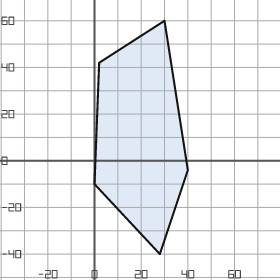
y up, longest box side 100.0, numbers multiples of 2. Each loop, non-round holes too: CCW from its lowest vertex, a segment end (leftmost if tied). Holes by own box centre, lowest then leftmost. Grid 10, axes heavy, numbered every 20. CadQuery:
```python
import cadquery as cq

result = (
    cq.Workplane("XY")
    .moveTo(28.0, -40.0)
    .lineTo(40.0, -4.0)
    .lineTo(30.0, 60.0)
    .lineTo(2.0, 42.0)
    .lineTo(0.0, -10.0)
    .close()
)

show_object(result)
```